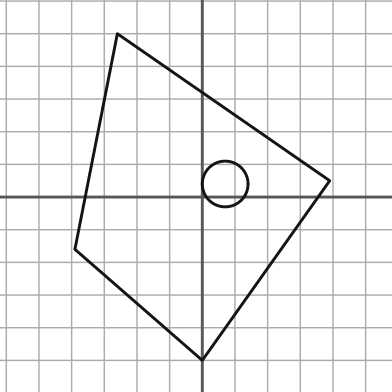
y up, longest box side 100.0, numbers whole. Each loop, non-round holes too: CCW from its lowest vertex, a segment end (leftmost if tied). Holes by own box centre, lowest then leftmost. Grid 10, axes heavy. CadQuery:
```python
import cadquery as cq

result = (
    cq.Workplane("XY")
    .moveTo(0.0, -50.0)
    .lineTo(39.0, 5.0)
    .lineTo(-26.0, 50.0)
    .lineTo(-39.0, -16.0)
    .close()
    .moveTo(7.0, 4.0)
    .circle(7.0)
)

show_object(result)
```